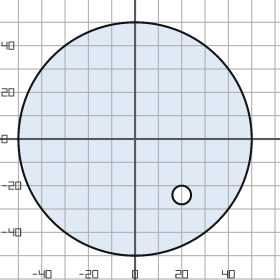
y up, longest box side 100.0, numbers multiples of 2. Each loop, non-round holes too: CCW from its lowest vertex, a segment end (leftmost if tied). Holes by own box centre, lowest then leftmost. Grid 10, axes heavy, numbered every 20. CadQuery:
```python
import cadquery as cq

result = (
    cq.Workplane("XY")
    .moveTo(0.0, 0.0)
    .circle(50.0)
    .moveTo(20.0, -24.0)
    .circle(4.0)
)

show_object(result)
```